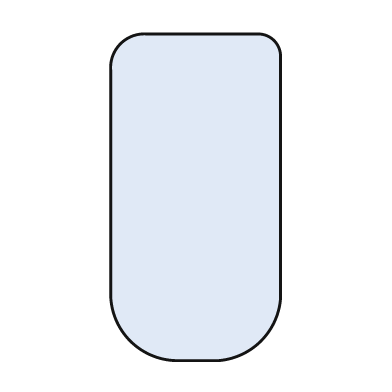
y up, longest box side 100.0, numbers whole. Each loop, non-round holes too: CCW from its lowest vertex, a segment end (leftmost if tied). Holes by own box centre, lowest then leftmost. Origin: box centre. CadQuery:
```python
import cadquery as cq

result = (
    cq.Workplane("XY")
    .moveTo(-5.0, -50.0)
    .lineTo(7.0, -50.0)
    .threePointArc((20.0, -44.0), (26.0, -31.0))
    .lineTo(26.0, 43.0)
    .threePointArc((24.0, 48.0), (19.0, 50.0))
    .lineTo(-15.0, 50.0)
    .threePointArc((-23.0, 47.0), (-26.0, 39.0))
    .lineTo(-26.0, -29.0)
    .threePointArc((-20.0, -44.0), (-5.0, -50.0))
    .close()
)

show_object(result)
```